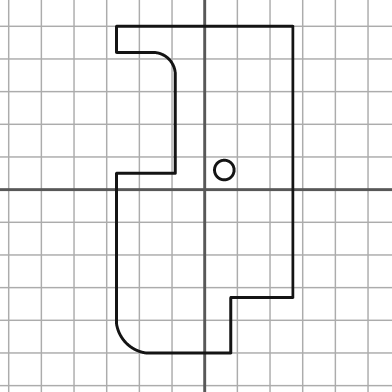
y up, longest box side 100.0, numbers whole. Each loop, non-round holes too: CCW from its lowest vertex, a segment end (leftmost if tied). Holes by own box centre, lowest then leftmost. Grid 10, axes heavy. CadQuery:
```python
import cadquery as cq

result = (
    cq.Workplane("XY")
    .moveTo(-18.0, -50.0)
    .lineTo(8.0, -50.0)
    .lineTo(8.0, -33.0)
    .lineTo(27.0, -33.0)
    .lineTo(27.0, 50.0)
    .lineTo(-27.0, 50.0)
    .lineTo(-27.0, 42.0)
    .lineTo(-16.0, 42.0)
    .threePointArc((-11.0, 40.0), (-9.0, 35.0))
    .lineTo(-9.0, 5.0)
    .lineTo(-27.0, 5.0)
    .lineTo(-27.0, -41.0)
    .threePointArc((-24.0, -47.0), (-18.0, -50.0))
    .close()
    .moveTo(6.0, 6.0)
    .circle(3.0)
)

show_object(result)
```